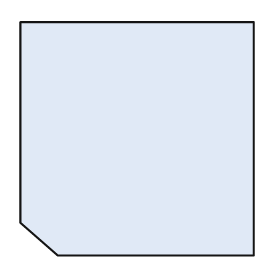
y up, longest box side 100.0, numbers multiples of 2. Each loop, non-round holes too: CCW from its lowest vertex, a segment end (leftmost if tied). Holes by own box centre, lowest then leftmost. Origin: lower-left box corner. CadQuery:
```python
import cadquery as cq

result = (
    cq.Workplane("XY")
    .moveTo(16.0, 0.0)
    .lineTo(100.0, 0.0)
    .lineTo(100.0, 100.0)
    .lineTo(0.0, 100.0)
    .lineTo(0.0, 14.0)
    .close()
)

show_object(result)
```